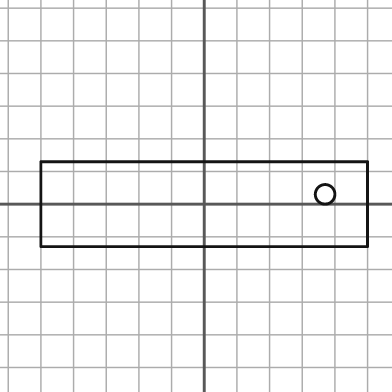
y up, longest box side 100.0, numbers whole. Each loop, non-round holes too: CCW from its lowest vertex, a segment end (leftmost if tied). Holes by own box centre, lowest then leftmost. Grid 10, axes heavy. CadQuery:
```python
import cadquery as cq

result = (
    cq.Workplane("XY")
    .moveTo(-50.0, -13.0)
    .lineTo(50.0, -13.0)
    .lineTo(50.0, 13.0)
    .lineTo(-50.0, 13.0)
    .close()
    .moveTo(37.0, 3.0)
    .circle(3.0)
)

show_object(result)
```